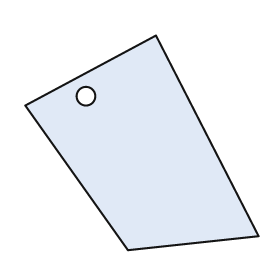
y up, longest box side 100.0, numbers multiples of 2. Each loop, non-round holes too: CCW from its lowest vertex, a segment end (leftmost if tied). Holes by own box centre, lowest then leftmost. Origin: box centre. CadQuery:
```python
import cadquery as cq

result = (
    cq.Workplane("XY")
    .moveTo(-6.0, -46.0)
    .lineTo(50.0, -40.0)
    .lineTo(6.0, 46.0)
    .lineTo(-50.0, 16.0)
    .close()
    .moveTo(-24.0, 20.0)
    .circle(4.0)
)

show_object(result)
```